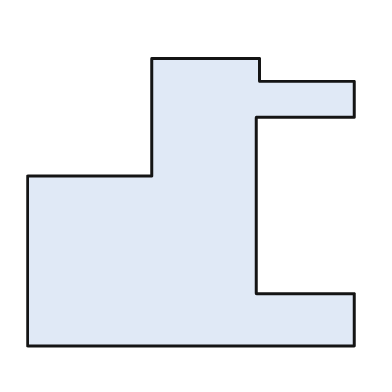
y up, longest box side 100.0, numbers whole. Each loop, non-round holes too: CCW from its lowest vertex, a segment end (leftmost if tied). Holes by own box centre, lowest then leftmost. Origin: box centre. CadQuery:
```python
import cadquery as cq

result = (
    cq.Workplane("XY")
    .moveTo(-50.0, -44.0)
    .lineTo(50.0, -44.0)
    .lineTo(50.0, -28.0)
    .lineTo(20.0, -28.0)
    .lineTo(20.0, 26.0)
    .lineTo(50.0, 26.0)
    .lineTo(50.0, 37.0)
    .lineTo(21.0, 37.0)
    .lineTo(21.0, 44.0)
    .lineTo(-12.0, 44.0)
    .lineTo(-12.0, 8.0)
    .lineTo(-50.0, 8.0)
    .close()
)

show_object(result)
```